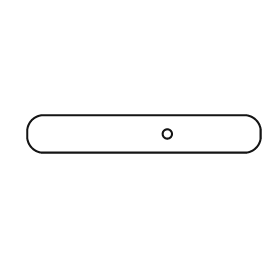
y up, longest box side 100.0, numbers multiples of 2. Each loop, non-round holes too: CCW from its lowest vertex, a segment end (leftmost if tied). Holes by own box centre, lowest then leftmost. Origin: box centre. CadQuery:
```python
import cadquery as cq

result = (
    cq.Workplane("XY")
    .moveTo(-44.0, -8.0)
    .lineTo(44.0, -8.0)
    .threePointArc((48.0, -6.0), (50.0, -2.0))
    .lineTo(50.0, 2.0)
    .threePointArc((48.0, 6.0), (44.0, 8.0))
    .lineTo(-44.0, 8.0)
    .threePointArc((-48.0, 6.0), (-50.0, 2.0))
    .lineTo(-50.0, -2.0)
    .threePointArc((-48.0, -6.0), (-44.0, -8.0))
    .close()
    .moveTo(10.0, 0.0)
    .circle(2.0)
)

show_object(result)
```